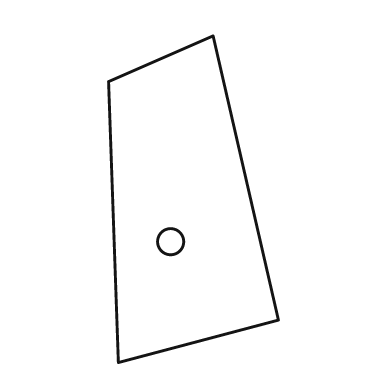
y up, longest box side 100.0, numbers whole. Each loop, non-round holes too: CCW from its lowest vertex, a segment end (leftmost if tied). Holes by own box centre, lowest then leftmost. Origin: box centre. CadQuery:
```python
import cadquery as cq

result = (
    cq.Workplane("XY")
    .moveTo(-23.0, -50.0)
    .lineTo(26.0, -37.0)
    .lineTo(6.0, 50.0)
    .lineTo(-26.0, 36.0)
    .close()
    .moveTo(-7.0, -13.0)
    .circle(4.0)
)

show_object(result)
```